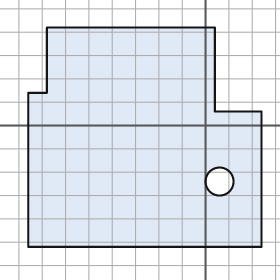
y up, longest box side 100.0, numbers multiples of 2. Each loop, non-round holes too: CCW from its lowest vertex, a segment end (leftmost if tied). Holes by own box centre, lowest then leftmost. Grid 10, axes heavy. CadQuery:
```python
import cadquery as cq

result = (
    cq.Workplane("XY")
    .moveTo(-76.0, -52.0)
    .lineTo(24.0, -52.0)
    .lineTo(24.0, 6.0)
    .lineTo(4.0, 6.0)
    .lineTo(4.0, 42.0)
    .lineTo(-68.0, 42.0)
    .lineTo(-68.0, 14.0)
    .lineTo(-76.0, 14.0)
    .close()
    .moveTo(6.0, -24.0)
    .circle(6.0)
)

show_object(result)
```